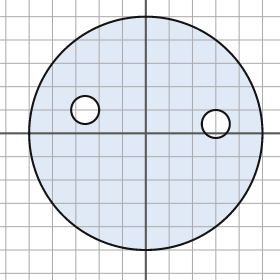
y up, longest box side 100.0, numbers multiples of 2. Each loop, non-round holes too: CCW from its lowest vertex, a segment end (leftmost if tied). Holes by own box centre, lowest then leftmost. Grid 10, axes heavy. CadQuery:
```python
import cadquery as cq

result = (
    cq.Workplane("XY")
    .moveTo(0.0, 0.0)
    .circle(50.0)
    .moveTo(30.0, 4.0)
    .circle(6.0)
    .moveTo(-26.0, 10.0)
    .circle(6.0)
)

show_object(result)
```